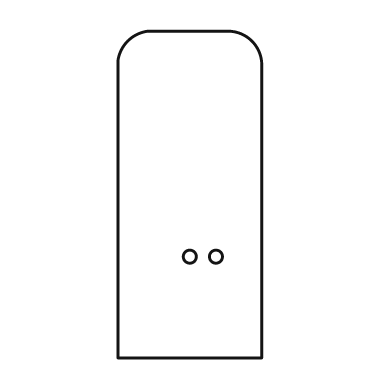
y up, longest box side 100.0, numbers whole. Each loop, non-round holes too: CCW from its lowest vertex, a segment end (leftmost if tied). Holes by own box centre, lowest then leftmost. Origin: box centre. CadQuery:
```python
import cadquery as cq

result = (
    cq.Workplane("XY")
    .moveTo(-22.0, -50.0)
    .lineTo(22.0, -50.0)
    .lineTo(22.0, 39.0)
    .threePointArc((19.0, 47.0), (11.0, 50.0))
    .lineTo(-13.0, 50.0)
    .threePointArc((-19.0, 47.0), (-22.0, 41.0))
    .close()
    .moveTo(0.0, -19.0)
    .circle(2.0)
    .moveTo(8.0, -19.0)
    .circle(2.0)
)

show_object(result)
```